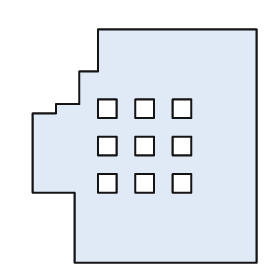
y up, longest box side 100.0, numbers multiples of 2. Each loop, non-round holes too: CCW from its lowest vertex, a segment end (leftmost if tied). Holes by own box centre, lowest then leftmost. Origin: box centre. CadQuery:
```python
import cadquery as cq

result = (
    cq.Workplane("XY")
    .moveTo(-30.0, -50.0)
    .lineTo(48.0, -50.0)
    .lineTo(48.0, 50.0)
    .lineTo(-20.0, 50.0)
    .lineTo(-20.0, 32.0)
    .lineTo(-28.0, 32.0)
    .lineTo(-28.0, 18.0)
    .lineTo(-38.0, 18.0)
    .lineTo(-38.0, 14.0)
    .lineTo(-48.0, 14.0)
    .lineTo(-48.0, -20.0)
    .lineTo(-30.0, -20.0)
    .close()
    .moveTo(-20.0, -20.0)
    .lineTo(-12.0, -20.0)
    .lineTo(-12.0, -12.0)
    .lineTo(-20.0, -12.0)
    .close()
    .moveTo(-4.0, -20.0)
    .lineTo(4.0, -20.0)
    .lineTo(4.0, -12.0)
    .lineTo(-4.0, -12.0)
    .close()
    .moveTo(12.0, -20.0)
    .lineTo(20.0, -20.0)
    .lineTo(20.0, -12.0)
    .lineTo(12.0, -12.0)
    .close()
    .moveTo(-20.0, -4.0)
    .lineTo(-12.0, -4.0)
    .lineTo(-12.0, 4.0)
    .lineTo(-20.0, 4.0)
    .close()
    .moveTo(-4.0, -4.0)
    .lineTo(4.0, -4.0)
    .lineTo(4.0, 4.0)
    .lineTo(-4.0, 4.0)
    .close()
    .moveTo(12.0, -4.0)
    .lineTo(20.0, -4.0)
    .lineTo(20.0, 4.0)
    .lineTo(12.0, 4.0)
    .close()
    .moveTo(-20.0, 12.0)
    .lineTo(-12.0, 12.0)
    .lineTo(-12.0, 20.0)
    .lineTo(-20.0, 20.0)
    .close()
    .moveTo(-4.0, 12.0)
    .lineTo(4.0, 12.0)
    .lineTo(4.0, 20.0)
    .lineTo(-4.0, 20.0)
    .close()
    .moveTo(12.0, 12.0)
    .lineTo(20.0, 12.0)
    .lineTo(20.0, 20.0)
    .lineTo(12.0, 20.0)
    .close()
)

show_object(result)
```